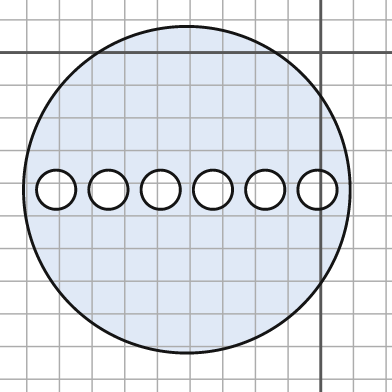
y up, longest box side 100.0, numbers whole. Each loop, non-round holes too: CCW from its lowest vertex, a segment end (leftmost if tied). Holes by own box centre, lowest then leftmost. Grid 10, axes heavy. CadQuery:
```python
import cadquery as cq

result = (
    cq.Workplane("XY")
    .moveTo(-41.0, -42.0)
    .circle(50.0)
    .moveTo(-81.0, -42.0)
    .circle(6.0)
    .moveTo(-65.0, -42.0)
    .circle(6.0)
    .moveTo(-49.0, -42.0)
    .circle(6.0)
    .moveTo(-33.0, -42.0)
    .circle(6.0)
    .moveTo(-17.0, -42.0)
    .circle(6.0)
    .moveTo(-1.0, -42.0)
    .circle(6.0)
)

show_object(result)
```